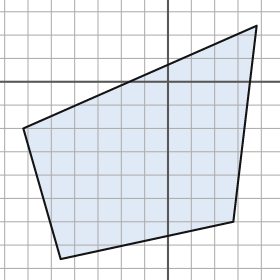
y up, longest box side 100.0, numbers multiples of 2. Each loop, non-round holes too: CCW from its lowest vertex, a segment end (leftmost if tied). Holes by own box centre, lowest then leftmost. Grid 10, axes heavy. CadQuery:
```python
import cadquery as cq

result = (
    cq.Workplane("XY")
    .moveTo(-46.0, -76.0)
    .lineTo(28.0, -60.0)
    .lineTo(38.0, 24.0)
    .lineTo(-62.0, -20.0)
    .close()
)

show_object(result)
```